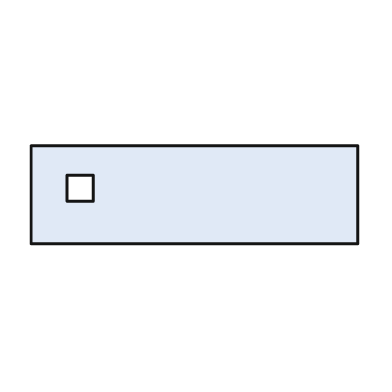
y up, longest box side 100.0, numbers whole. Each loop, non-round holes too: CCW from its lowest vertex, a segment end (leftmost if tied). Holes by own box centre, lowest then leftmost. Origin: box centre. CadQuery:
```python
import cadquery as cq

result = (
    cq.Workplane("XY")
    .moveTo(-50.0, -15.0)
    .lineTo(50.0, -15.0)
    .lineTo(50.0, 15.0)
    .lineTo(-50.0, 15.0)
    .close()
    .moveTo(-39.0, -2.0)
    .lineTo(-31.0, -2.0)
    .lineTo(-31.0, 6.0)
    .lineTo(-39.0, 6.0)
    .close()
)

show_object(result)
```